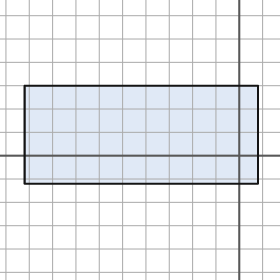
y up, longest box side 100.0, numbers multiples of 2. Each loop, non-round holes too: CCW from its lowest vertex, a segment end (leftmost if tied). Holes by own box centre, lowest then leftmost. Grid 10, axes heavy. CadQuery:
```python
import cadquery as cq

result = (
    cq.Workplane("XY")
    .moveTo(-92.0, -12.0)
    .lineTo(8.0, -12.0)
    .lineTo(8.0, 30.0)
    .lineTo(-92.0, 30.0)
    .close()
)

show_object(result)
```